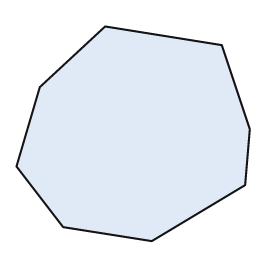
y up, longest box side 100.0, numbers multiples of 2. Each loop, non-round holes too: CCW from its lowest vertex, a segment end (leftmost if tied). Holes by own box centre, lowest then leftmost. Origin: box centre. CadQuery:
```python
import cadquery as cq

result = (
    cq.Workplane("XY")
    .moveTo(8.0, -46.0)
    .lineTo(48.0, -22.0)
    .lineTo(50.0, 2.0)
    .lineTo(38.0, 38.0)
    .lineTo(-12.0, 46.0)
    .lineTo(-40.0, 20.0)
    .lineTo(-50.0, -14.0)
    .lineTo(-30.0, -40.0)
    .close()
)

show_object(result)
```